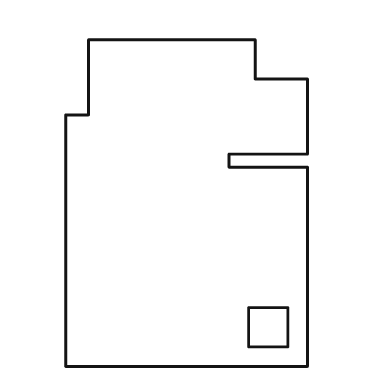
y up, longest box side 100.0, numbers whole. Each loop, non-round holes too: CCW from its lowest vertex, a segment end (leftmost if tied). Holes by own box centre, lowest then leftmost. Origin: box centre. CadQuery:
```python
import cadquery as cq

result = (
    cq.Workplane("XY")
    .moveTo(-37.0, -50.0)
    .lineTo(37.0, -50.0)
    .lineTo(37.0, 11.0)
    .lineTo(13.0, 11.0)
    .lineTo(13.0, 15.0)
    .lineTo(37.0, 15.0)
    .lineTo(37.0, 38.0)
    .lineTo(21.0, 38.0)
    .lineTo(21.0, 50.0)
    .lineTo(-30.0, 50.0)
    .lineTo(-30.0, 27.0)
    .lineTo(-37.0, 27.0)
    .close()
    .moveTo(19.0, -44.0)
    .lineTo(31.0, -44.0)
    .lineTo(31.0, -32.0)
    .lineTo(19.0, -32.0)
    .close()
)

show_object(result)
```